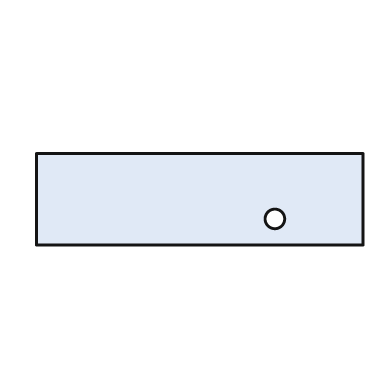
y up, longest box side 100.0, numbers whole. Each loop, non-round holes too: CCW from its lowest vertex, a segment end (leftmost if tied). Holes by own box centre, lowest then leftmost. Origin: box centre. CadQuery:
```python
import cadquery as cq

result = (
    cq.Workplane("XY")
    .moveTo(-50.0, -14.0)
    .lineTo(50.0, -14.0)
    .lineTo(50.0, 14.0)
    .lineTo(-50.0, 14.0)
    .close()
    .moveTo(23.0, -6.0)
    .circle(3.0)
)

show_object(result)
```